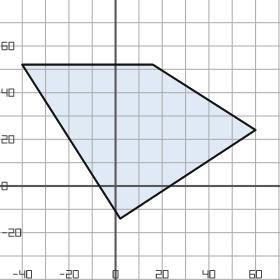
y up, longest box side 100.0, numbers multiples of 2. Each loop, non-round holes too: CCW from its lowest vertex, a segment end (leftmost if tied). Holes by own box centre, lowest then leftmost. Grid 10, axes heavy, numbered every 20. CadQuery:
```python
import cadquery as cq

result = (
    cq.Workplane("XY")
    .moveTo(2.0, -14.0)
    .lineTo(60.0, 24.0)
    .lineTo(16.0, 52.0)
    .lineTo(-40.0, 52.0)
    .close()
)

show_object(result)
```